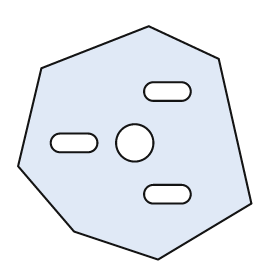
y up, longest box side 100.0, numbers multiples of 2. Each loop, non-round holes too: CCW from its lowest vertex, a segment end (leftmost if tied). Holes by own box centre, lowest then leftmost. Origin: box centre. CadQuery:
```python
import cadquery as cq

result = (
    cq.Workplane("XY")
    .moveTo(10.0, -50.0)
    .lineTo(50.0, -26.0)
    .lineTo(36.0, 36.0)
    .lineTo(6.0, 50.0)
    .lineTo(-40.0, 32.0)
    .lineTo(-50.0, -10.0)
    .lineTo(-26.0, -38.0)
    .close()
    .moveTo(8.0, -26.0)
    .lineTo(20.0, -26.0)
    .threePointArc((24.0, -22.0), (20.0, -18.0))
    .lineTo(8.0, -18.0)
    .threePointArc((4.0, -22.0), (8.0, -26.0))
    .close()
    .moveTo(-32.0, -4.0)
    .lineTo(-20.0, -4.0)
    .threePointArc((-16.0, 0.0), (-20.0, 4.0))
    .lineTo(-32.0, 4.0)
    .threePointArc((-36.0, 0.0), (-32.0, -4.0))
    .close()
    .moveTo(0.0, 0.0)
    .circle(8.0)
    .moveTo(8.0, 18.0)
    .lineTo(20.0, 18.0)
    .threePointArc((24.0, 22.0), (20.0, 26.0))
    .lineTo(8.0, 26.0)
    .threePointArc((4.0, 22.0), (8.0, 18.0))
    .close()
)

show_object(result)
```